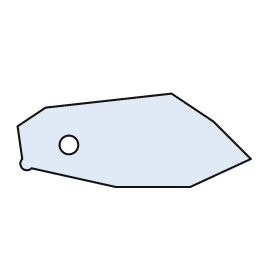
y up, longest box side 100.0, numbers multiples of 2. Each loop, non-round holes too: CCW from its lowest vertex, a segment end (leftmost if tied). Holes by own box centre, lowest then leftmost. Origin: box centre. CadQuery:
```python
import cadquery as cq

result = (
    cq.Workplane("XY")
    .moveTo(-8.0, -20.0)
    .lineTo(24.0, -20.0)
    .lineTo(50.0, -8.0)
    .lineTo(34.0, 8.0)
    .lineTo(16.0, 20.0)
    .lineTo(-38.0, 14.0)
    .lineTo(-50.0, 6.0)
    .lineTo(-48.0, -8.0)
    .threePointArc((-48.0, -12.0), (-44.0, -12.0))
    .close()
    .moveTo(-28.0, -2.0)
    .circle(4.0)
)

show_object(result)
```